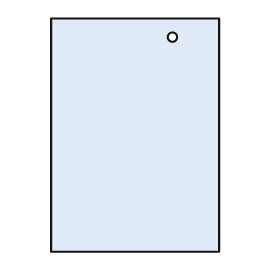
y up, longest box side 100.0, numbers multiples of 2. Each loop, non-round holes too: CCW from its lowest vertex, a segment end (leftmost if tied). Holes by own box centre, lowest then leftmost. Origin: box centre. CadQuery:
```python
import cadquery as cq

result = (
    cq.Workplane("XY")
    .moveTo(-36.0, -50.0)
    .lineTo(36.0, -50.0)
    .lineTo(36.0, 50.0)
    .lineTo(-36.0, 50.0)
    .close()
    .moveTo(16.0, 42.0)
    .circle(2.0)
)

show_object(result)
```